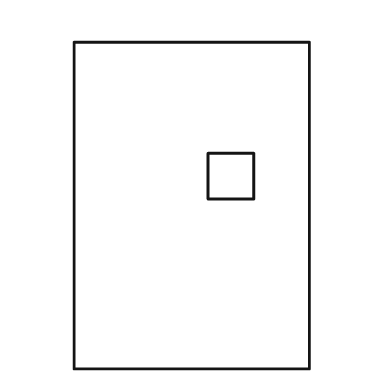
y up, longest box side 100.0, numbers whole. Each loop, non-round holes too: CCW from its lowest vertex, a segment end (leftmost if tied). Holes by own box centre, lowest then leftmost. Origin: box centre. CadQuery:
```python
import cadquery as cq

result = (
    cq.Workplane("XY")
    .moveTo(-36.0, -50.0)
    .lineTo(36.0, -50.0)
    .lineTo(36.0, 50.0)
    .lineTo(-36.0, 50.0)
    .close()
    .moveTo(5.0, 2.0)
    .lineTo(19.0, 2.0)
    .lineTo(19.0, 16.0)
    .lineTo(5.0, 16.0)
    .close()
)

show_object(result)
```